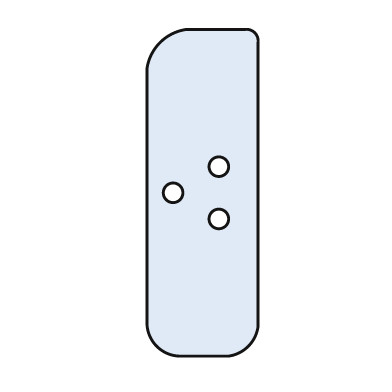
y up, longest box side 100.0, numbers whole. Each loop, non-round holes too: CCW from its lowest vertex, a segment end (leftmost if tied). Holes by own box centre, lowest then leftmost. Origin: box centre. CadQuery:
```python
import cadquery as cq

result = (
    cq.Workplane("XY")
    .moveTo(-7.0, -50.0)
    .lineTo(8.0, -50.0)
    .threePointArc((14.0, -47.0), (17.0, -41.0))
    .lineTo(17.0, 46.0)
    .threePointArc((16.0, 49.0), (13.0, 50.0))
    .lineTo(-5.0, 50.0)
    .threePointArc((-13.0, 46.0), (-17.0, 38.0))
    .lineTo(-17.0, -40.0)
    .threePointArc((-14.0, -47.0), (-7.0, -50.0))
    .close()
    .moveTo(5.0, -8.0)
    .circle(3.0)
    .moveTo(-9.0, 0.0)
    .circle(3.0)
    .moveTo(5.0, 8.0)
    .circle(3.0)
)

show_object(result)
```